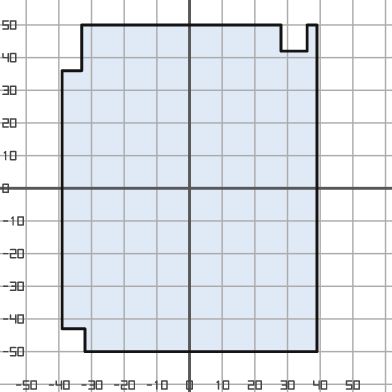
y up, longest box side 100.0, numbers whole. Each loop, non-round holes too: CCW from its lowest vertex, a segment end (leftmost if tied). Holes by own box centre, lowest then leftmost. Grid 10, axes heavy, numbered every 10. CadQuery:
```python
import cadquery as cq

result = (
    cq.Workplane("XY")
    .moveTo(-32.0, -50.0)
    .lineTo(39.0, -50.0)
    .lineTo(39.0, 50.0)
    .lineTo(36.0, 50.0)
    .lineTo(36.0, 42.0)
    .lineTo(28.0, 42.0)
    .lineTo(28.0, 50.0)
    .lineTo(-33.0, 50.0)
    .lineTo(-33.0, 36.0)
    .lineTo(-39.0, 36.0)
    .lineTo(-39.0, -43.0)
    .lineTo(-32.0, -43.0)
    .close()
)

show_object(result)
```